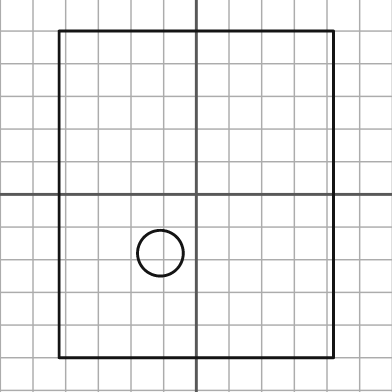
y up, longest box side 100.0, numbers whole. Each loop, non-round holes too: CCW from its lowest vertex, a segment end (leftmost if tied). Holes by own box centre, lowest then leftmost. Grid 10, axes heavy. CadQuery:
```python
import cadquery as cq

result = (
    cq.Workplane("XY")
    .moveTo(-42.0, -50.0)
    .lineTo(42.0, -50.0)
    .lineTo(42.0, 50.0)
    .lineTo(-42.0, 50.0)
    .close()
    .moveTo(-11.0, -18.0)
    .circle(7.0)
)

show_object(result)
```